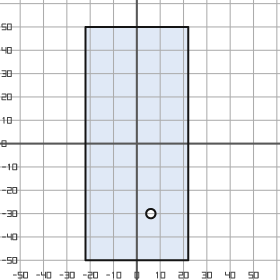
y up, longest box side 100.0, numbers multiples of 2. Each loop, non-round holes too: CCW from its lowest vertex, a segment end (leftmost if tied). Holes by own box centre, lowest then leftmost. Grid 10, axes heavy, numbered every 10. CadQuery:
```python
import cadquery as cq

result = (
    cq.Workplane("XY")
    .moveTo(-22.0, -50.0)
    .lineTo(22.0, -50.0)
    .lineTo(22.0, 50.0)
    .lineTo(-22.0, 50.0)
    .close()
    .moveTo(6.0, -30.0)
    .circle(2.0)
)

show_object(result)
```